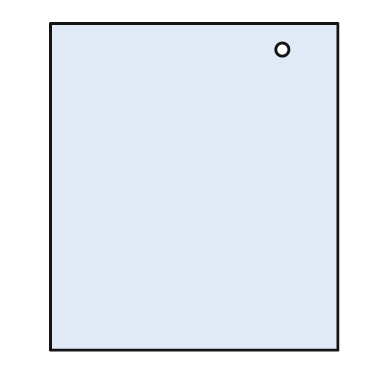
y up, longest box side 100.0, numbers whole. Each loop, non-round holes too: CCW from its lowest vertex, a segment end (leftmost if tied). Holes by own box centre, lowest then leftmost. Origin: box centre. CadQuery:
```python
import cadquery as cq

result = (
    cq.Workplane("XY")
    .moveTo(-44.0, -50.0)
    .lineTo(44.0, -50.0)
    .lineTo(44.0, 50.0)
    .lineTo(-44.0, 50.0)
    .close()
    .moveTo(27.0, 42.0)
    .circle(2.0)
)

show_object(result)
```